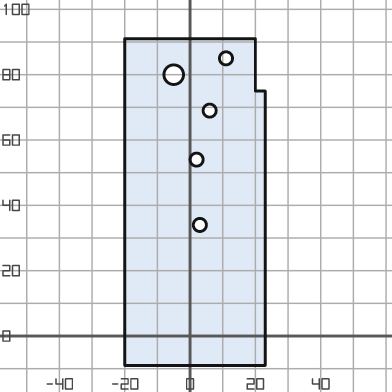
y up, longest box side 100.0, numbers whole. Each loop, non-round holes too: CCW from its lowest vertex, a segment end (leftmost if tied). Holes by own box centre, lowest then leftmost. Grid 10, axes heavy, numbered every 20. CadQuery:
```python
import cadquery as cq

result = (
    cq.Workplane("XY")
    .moveTo(-20.0, -9.0)
    .lineTo(23.0, -9.0)
    .lineTo(23.0, 75.0)
    .lineTo(20.0, 75.0)
    .lineTo(20.0, 91.0)
    .lineTo(-20.0, 91.0)
    .close()
    .moveTo(3.0, 34.0)
    .circle(2.0)
    .moveTo(2.0, 54.0)
    .circle(2.0)
    .moveTo(6.0, 69.0)
    .circle(2.0)
    .moveTo(-5.0, 80.0)
    .circle(3.0)
    .moveTo(11.0, 85.0)
    .circle(2.0)
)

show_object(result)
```